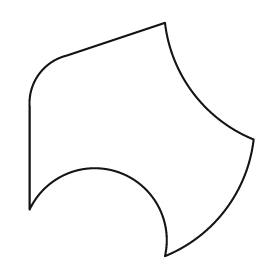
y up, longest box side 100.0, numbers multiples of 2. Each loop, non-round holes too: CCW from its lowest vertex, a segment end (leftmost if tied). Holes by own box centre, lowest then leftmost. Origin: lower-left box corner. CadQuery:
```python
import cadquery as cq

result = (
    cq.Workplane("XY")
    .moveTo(58.0, 0.0)
    .threePointArc((84.0, 20.0), (96.0, 50.0))
    .threePointArc((70.0, 70.0), (58.0, 100.0))
    .lineTo(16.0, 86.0)
    .threePointArc((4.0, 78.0), (0.0, 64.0))
    .lineTo(0.0, 20.0)
    .threePointArc((38.0, 36.0), (58.0, 0.0))
    .close()
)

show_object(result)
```